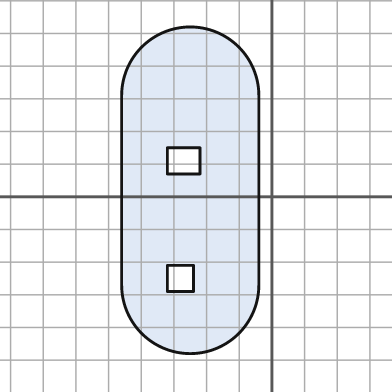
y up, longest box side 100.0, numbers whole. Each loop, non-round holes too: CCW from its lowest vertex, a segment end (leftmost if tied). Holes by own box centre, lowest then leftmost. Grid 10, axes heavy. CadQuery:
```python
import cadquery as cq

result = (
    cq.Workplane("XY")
    .moveTo(-46.0, -27.0)
    .threePointArc((-25.0, -48.0), (-4.0, -27.0))
    .lineTo(-4.0, 31.0)
    .threePointArc((-25.0, 52.0), (-46.0, 31.0))
    .close()
    .moveTo(-32.0, -29.0)
    .lineTo(-24.0, -29.0)
    .lineTo(-24.0, -21.0)
    .lineTo(-32.0, -21.0)
    .close()
    .moveTo(-32.0, 7.0)
    .lineTo(-22.0, 7.0)
    .lineTo(-22.0, 15.0)
    .lineTo(-32.0, 15.0)
    .close()
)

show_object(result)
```